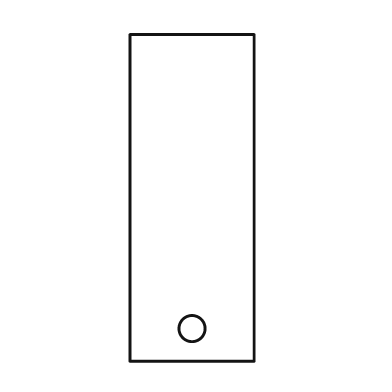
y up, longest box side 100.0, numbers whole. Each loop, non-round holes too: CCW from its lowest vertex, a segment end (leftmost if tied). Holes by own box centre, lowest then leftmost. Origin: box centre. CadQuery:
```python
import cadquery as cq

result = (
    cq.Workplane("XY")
    .moveTo(-19.0, -50.0)
    .lineTo(19.0, -50.0)
    .lineTo(19.0, 50.0)
    .lineTo(-19.0, 50.0)
    .close()
    .moveTo(0.0, -40.0)
    .circle(4.0)
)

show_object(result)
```